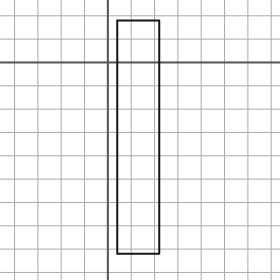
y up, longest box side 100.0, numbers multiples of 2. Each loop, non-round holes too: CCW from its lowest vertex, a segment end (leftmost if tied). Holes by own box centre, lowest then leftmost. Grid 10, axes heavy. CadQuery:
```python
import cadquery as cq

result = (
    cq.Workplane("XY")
    .moveTo(4.0, -82.0)
    .lineTo(22.0, -82.0)
    .lineTo(22.0, 18.0)
    .lineTo(4.0, 18.0)
    .close()
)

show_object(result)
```